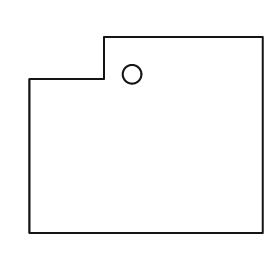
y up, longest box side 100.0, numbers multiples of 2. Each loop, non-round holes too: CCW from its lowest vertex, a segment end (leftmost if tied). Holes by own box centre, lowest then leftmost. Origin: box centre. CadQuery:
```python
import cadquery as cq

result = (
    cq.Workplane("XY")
    .moveTo(-50.0, -42.0)
    .lineTo(50.0, -42.0)
    .lineTo(50.0, 42.0)
    .lineTo(-18.0, 42.0)
    .lineTo(-18.0, 24.0)
    .lineTo(-50.0, 24.0)
    .close()
    .moveTo(-6.0, 26.0)
    .circle(4.0)
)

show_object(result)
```